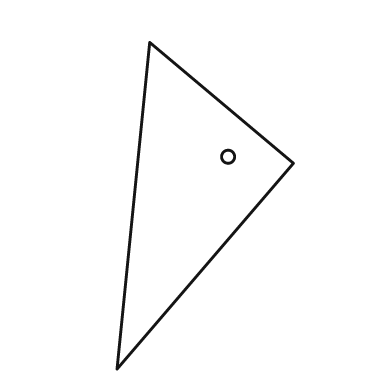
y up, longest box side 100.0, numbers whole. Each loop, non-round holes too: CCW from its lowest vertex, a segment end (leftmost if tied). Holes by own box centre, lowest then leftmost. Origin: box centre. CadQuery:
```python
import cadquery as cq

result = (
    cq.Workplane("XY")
    .moveTo(-27.0, -50.0)
    .lineTo(27.0, 13.0)
    .lineTo(-17.0, 50.0)
    .close()
    .moveTo(7.0, 15.0)
    .circle(2.0)
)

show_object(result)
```